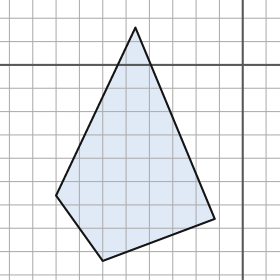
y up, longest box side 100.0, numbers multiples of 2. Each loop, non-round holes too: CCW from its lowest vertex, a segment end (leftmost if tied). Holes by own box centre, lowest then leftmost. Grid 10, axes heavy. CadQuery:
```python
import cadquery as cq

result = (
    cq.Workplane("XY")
    .moveTo(-60.0, -84.0)
    .lineTo(-12.0, -66.0)
    .lineTo(-46.0, 16.0)
    .lineTo(-80.0, -56.0)
    .close()
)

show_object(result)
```